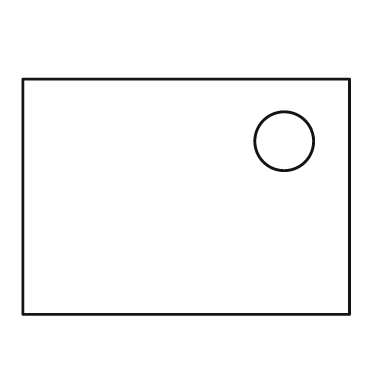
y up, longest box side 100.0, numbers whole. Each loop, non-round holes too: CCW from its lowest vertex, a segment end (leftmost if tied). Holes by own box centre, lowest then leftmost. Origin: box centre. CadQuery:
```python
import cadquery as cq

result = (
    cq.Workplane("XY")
    .moveTo(-50.0, -36.0)
    .lineTo(50.0, -36.0)
    .lineTo(50.0, 36.0)
    .lineTo(-50.0, 36.0)
    .close()
    .moveTo(30.0, 17.0)
    .circle(9.0)
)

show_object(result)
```